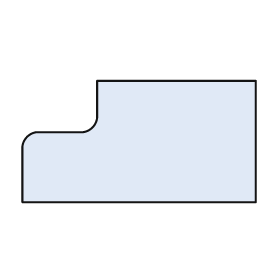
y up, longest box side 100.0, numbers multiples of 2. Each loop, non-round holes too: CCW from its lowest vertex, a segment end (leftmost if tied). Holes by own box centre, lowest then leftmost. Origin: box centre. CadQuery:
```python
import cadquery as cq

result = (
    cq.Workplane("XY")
    .moveTo(-50.0, -26.0)
    .lineTo(50.0, -26.0)
    .lineTo(50.0, 26.0)
    .lineTo(-18.0, 26.0)
    .lineTo(-18.0, 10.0)
    .threePointArc((-20.0, 6.0), (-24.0, 4.0))
    .lineTo(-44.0, 4.0)
    .threePointArc((-48.0, 2.0), (-50.0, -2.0))
    .close()
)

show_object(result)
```